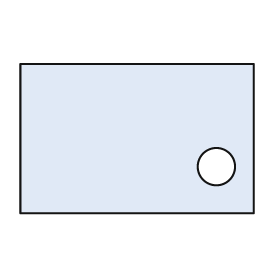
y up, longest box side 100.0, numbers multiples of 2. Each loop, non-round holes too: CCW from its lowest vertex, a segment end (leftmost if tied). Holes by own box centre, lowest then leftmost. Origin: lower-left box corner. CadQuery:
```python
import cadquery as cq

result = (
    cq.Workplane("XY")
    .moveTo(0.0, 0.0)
    .lineTo(100.0, 0.0)
    .lineTo(100.0, 64.0)
    .lineTo(0.0, 64.0)
    .close()
    .moveTo(84.0, 20.0)
    .circle(8.0)
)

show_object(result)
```